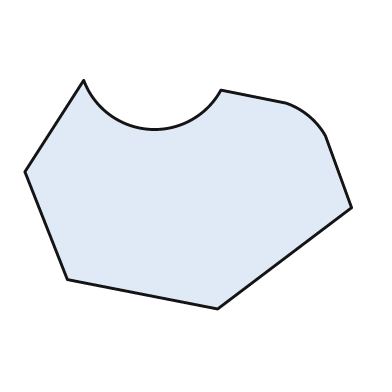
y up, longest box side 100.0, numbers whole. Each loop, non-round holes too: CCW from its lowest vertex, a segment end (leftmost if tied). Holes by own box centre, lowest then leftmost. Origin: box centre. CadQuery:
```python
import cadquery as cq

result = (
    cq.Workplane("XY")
    .moveTo(9.0, -35.0)
    .lineTo(50.0, -4.0)
    .lineTo(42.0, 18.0)
    .threePointArc((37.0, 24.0), (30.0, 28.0))
    .lineTo(10.0, 32.0)
    .threePointArc((-12.0, 20.0), (-32.0, 35.0))
    .lineTo(-50.0, 7.0)
    .lineTo(-37.0, -26.0)
    .close()
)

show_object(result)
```